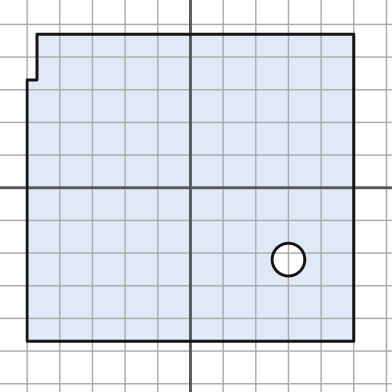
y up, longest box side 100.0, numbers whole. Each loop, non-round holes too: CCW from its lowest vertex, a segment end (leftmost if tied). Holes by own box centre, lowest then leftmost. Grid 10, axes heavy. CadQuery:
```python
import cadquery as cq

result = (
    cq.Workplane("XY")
    .moveTo(-50.0, -47.0)
    .lineTo(50.0, -47.0)
    .lineTo(50.0, 47.0)
    .lineTo(-47.0, 47.0)
    .lineTo(-47.0, 33.0)
    .lineTo(-50.0, 33.0)
    .close()
    .moveTo(30.0, -22.0)
    .circle(5.0)
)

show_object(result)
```